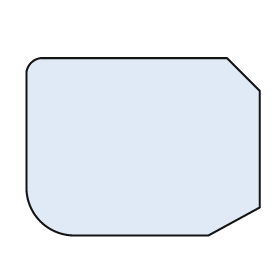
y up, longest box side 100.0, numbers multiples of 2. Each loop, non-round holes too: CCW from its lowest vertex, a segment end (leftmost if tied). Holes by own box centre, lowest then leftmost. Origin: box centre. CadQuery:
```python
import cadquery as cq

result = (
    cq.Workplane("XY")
    .moveTo(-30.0, -38.0)
    .lineTo(28.0, -38.0)
    .lineTo(50.0, -26.0)
    .lineTo(50.0, 24.0)
    .lineTo(36.0, 38.0)
    .lineTo(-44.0, 38.0)
    .threePointArc((-48.0, 36.0), (-50.0, 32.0))
    .lineTo(-50.0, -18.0)
    .threePointArc((-44.0, -32.0), (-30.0, -38.0))
    .close()
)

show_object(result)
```